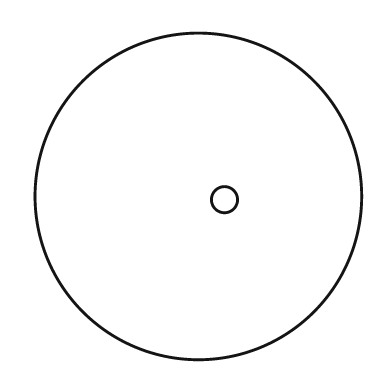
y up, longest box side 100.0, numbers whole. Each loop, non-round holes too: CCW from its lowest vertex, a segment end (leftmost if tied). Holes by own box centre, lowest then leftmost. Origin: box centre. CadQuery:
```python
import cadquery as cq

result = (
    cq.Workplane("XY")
    .moveTo(0.0, 0.0)
    .circle(50.0)
    .moveTo(8.0, -1.0)
    .circle(4.0)
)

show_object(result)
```